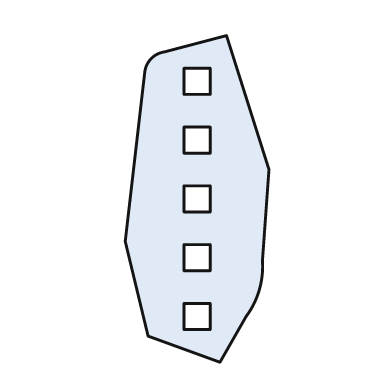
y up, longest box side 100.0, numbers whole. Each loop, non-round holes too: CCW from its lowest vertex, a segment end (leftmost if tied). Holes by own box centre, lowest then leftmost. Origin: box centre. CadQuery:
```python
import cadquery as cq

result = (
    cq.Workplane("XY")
    .moveTo(7.0, -50.0)
    .lineTo(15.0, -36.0)
    .threePointArc((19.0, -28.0), (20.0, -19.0))
    .lineTo(22.0, 9.0)
    .lineTo(9.0, 50.0)
    .lineTo(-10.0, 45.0)
    .threePointArc((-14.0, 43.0), (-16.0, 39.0))
    .lineTo(-22.0, -13.0)
    .lineTo(-15.0, -42.0)
    .close()
    .moveTo(-4.0, -40.0)
    .lineTo(4.0, -40.0)
    .lineTo(4.0, -32.0)
    .lineTo(-4.0, -32.0)
    .close()
    .moveTo(-4.0, -22.0)
    .lineTo(4.0, -22.0)
    .lineTo(4.0, -14.0)
    .lineTo(-4.0, -14.0)
    .close()
    .moveTo(-4.0, -4.0)
    .lineTo(4.0, -4.0)
    .lineTo(4.0, 4.0)
    .lineTo(-4.0, 4.0)
    .close()
    .moveTo(-4.0, 14.0)
    .lineTo(4.0, 14.0)
    .lineTo(4.0, 22.0)
    .lineTo(-4.0, 22.0)
    .close()
    .moveTo(-4.0, 32.0)
    .lineTo(4.0, 32.0)
    .lineTo(4.0, 40.0)
    .lineTo(-4.0, 40.0)
    .close()
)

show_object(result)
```